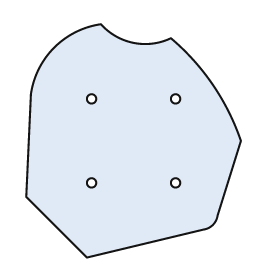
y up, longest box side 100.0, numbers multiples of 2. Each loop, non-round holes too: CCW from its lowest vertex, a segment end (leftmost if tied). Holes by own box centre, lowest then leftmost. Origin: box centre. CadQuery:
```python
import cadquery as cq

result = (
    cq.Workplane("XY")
    .moveTo(-20.0, -50.0)
    .lineTo(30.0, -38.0)
    .threePointArc((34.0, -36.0), (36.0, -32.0))
    .lineTo(46.0, 0.0)
    .threePointArc((34.0, 24.0), (16.0, 44.0))
    .threePointArc((0.0, 42.0), (-14.0, 50.0))
    .threePointArc((-34.0, 40.0), (-44.0, 20.0))
    .lineTo(-46.0, -24.0)
    .close()
    .moveTo(-18.0, -18.0)
    .circle(2.0)
    .moveTo(18.0, -18.0)
    .circle(2.0)
    .moveTo(-18.0, 18.0)
    .circle(2.0)
    .moveTo(18.0, 18.0)
    .circle(2.0)
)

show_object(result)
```